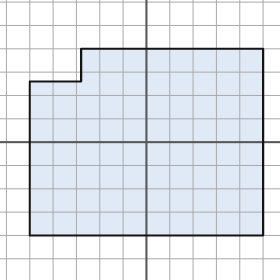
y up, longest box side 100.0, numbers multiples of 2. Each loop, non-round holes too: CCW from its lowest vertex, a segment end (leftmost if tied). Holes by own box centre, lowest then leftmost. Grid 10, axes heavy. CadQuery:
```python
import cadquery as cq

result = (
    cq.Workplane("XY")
    .moveTo(-50.0, -40.0)
    .lineTo(50.0, -40.0)
    .lineTo(50.0, 40.0)
    .lineTo(-28.0, 40.0)
    .lineTo(-28.0, 26.0)
    .lineTo(-50.0, 26.0)
    .close()
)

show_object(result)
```